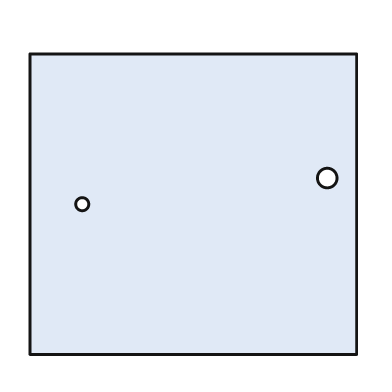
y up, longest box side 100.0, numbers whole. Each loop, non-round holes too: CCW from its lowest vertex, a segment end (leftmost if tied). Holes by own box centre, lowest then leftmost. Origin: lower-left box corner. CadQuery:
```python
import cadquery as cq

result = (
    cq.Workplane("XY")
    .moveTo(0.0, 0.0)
    .lineTo(100.0, 0.0)
    .lineTo(100.0, 92.0)
    .lineTo(0.0, 92.0)
    .close()
    .moveTo(16.0, 46.0)
    .circle(2.0)
    .moveTo(91.0, 54.0)
    .circle(3.0)
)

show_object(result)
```